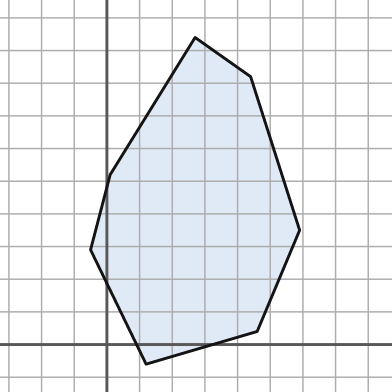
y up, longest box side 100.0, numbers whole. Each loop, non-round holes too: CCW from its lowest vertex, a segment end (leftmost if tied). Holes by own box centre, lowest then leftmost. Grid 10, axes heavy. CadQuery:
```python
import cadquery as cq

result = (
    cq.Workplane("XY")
    .moveTo(12.0, -6.0)
    .lineTo(46.0, 4.0)
    .lineTo(59.0, 35.0)
    .lineTo(44.0, 82.0)
    .lineTo(27.0, 94.0)
    .lineTo(1.0, 52.0)
    .lineTo(-5.0, 29.0)
    .close()
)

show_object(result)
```